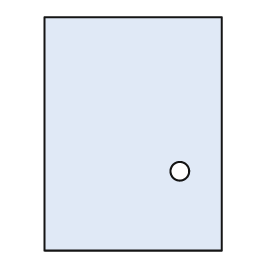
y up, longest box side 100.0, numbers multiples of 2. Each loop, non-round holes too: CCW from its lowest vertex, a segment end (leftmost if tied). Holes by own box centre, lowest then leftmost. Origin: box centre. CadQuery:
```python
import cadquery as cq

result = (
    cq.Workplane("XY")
    .moveTo(-38.0, -50.0)
    .lineTo(38.0, -50.0)
    .lineTo(38.0, 50.0)
    .lineTo(-38.0, 50.0)
    .close()
    .moveTo(20.0, -16.0)
    .circle(4.0)
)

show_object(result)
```